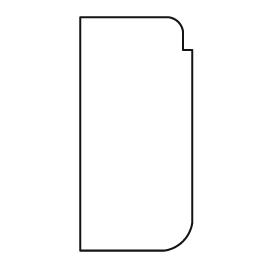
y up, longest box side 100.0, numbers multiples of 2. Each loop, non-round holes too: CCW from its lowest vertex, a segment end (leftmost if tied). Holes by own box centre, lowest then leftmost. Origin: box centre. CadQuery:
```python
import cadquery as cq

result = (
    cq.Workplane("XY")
    .moveTo(-24.0, -50.0)
    .lineTo(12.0, -50.0)
    .threePointArc((20.0, -46.0), (24.0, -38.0))
    .lineTo(24.0, 36.0)
    .lineTo(20.0, 36.0)
    .lineTo(20.0, 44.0)
    .threePointArc((18.0, 48.0), (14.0, 50.0))
    .lineTo(-24.0, 50.0)
    .close()
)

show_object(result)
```